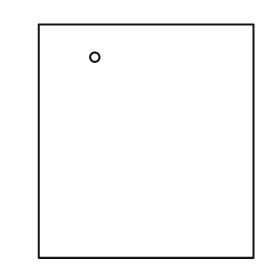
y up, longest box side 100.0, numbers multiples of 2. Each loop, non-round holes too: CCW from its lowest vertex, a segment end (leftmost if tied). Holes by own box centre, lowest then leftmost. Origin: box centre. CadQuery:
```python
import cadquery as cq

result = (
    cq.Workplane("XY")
    .moveTo(-46.0, -50.0)
    .lineTo(46.0, -50.0)
    .lineTo(46.0, 50.0)
    .lineTo(-46.0, 50.0)
    .close()
    .moveTo(-22.0, 36.0)
    .circle(2.0)
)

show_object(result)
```